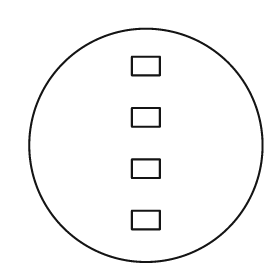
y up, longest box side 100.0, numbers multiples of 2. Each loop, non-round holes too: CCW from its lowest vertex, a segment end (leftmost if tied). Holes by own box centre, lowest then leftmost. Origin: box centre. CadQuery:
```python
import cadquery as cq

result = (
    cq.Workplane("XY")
    .moveTo(0.0, 0.0)
    .circle(50.0)
    .moveTo(-6.0, -36.0)
    .lineTo(6.0, -36.0)
    .lineTo(6.0, -28.0)
    .lineTo(-6.0, -28.0)
    .close()
    .moveTo(-6.0, -14.0)
    .lineTo(6.0, -14.0)
    .lineTo(6.0, -6.0)
    .lineTo(-6.0, -6.0)
    .close()
    .moveTo(-6.0, 8.0)
    .lineTo(6.0, 8.0)
    .lineTo(6.0, 16.0)
    .lineTo(-6.0, 16.0)
    .close()
    .moveTo(-6.0, 30.0)
    .lineTo(6.0, 30.0)
    .lineTo(6.0, 38.0)
    .lineTo(-6.0, 38.0)
    .close()
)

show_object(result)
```